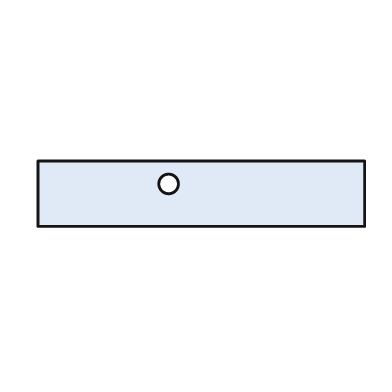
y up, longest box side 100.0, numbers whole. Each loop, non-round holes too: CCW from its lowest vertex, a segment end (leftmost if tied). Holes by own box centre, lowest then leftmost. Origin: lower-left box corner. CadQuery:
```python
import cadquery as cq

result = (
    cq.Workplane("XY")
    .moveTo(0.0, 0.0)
    .lineTo(100.0, 0.0)
    .lineTo(100.0, 20.0)
    .lineTo(0.0, 20.0)
    .close()
    .moveTo(40.0, 13.0)
    .circle(3.0)
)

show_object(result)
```